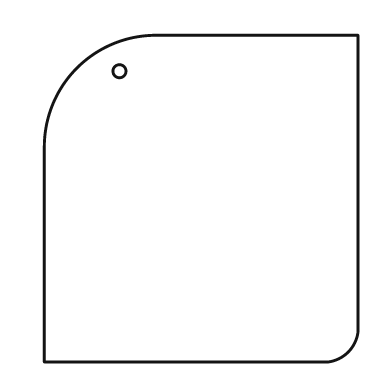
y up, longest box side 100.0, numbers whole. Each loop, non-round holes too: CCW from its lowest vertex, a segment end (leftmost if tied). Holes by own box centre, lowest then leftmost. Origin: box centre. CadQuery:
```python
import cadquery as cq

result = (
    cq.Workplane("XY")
    .moveTo(-48.0, -50.0)
    .lineTo(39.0, -50.0)
    .threePointArc((45.0, -47.0), (48.0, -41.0))
    .lineTo(48.0, 50.0)
    .lineTo(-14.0, 50.0)
    .threePointArc((-38.0, 40.0), (-48.0, 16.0))
    .close()
    .moveTo(-25.0, 39.0)
    .circle(2.0)
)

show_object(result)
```